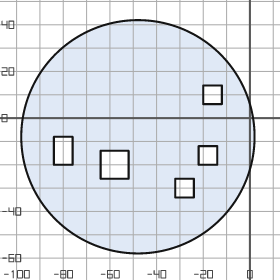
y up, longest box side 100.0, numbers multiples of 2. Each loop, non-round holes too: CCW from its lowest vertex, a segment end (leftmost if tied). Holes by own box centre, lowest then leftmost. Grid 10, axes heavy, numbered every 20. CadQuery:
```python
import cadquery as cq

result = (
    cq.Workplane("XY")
    .moveTo(-48.0, -8.0)
    .circle(50.0)
    .moveTo(-32.0, -34.0)
    .lineTo(-24.0, -34.0)
    .lineTo(-24.0, -26.0)
    .lineTo(-32.0, -26.0)
    .close()
    .moveTo(-64.0, -26.0)
    .lineTo(-52.0, -26.0)
    .lineTo(-52.0, -14.0)
    .lineTo(-64.0, -14.0)
    .close()
    .moveTo(-22.0, -20.0)
    .lineTo(-14.0, -20.0)
    .lineTo(-14.0, -12.0)
    .lineTo(-22.0, -12.0)
    .close()
    .moveTo(-84.0, -20.0)
    .lineTo(-76.0, -20.0)
    .lineTo(-76.0, -8.0)
    .lineTo(-84.0, -8.0)
    .close()
    .moveTo(-20.0, 6.0)
    .lineTo(-12.0, 6.0)
    .lineTo(-12.0, 14.0)
    .lineTo(-20.0, 14.0)
    .close()
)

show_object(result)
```